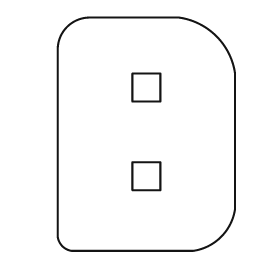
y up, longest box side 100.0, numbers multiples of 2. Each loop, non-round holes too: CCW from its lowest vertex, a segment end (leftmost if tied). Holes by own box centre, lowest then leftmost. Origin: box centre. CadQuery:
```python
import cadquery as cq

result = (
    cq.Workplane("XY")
    .moveTo(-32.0, -50.0)
    .lineTo(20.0, -50.0)
    .threePointArc((32.0, -44.0), (38.0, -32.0))
    .lineTo(38.0, 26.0)
    .threePointArc((30.0, 42.0), (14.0, 50.0))
    .lineTo(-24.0, 50.0)
    .threePointArc((-34.0, 46.0), (-38.0, 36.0))
    .lineTo(-38.0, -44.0)
    .threePointArc((-36.0, -48.0), (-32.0, -50.0))
    .close()
    .moveTo(-6.0, -24.0)
    .lineTo(6.0, -24.0)
    .lineTo(6.0, -12.0)
    .lineTo(-6.0, -12.0)
    .close()
    .moveTo(-6.0, 14.0)
    .lineTo(6.0, 14.0)
    .lineTo(6.0, 26.0)
    .lineTo(-6.0, 26.0)
    .close()
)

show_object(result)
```